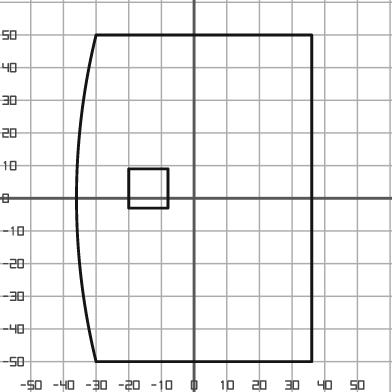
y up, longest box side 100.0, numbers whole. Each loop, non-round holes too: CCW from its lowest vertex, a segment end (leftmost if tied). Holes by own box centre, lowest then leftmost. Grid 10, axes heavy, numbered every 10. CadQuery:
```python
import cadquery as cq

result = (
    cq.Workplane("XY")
    .moveTo(-30.0, -50.0)
    .lineTo(36.0, -50.0)
    .lineTo(36.0, 50.0)
    .lineTo(-30.0, 50.0)
    .threePointArc((-36.0, 0.0), (-30.0, -50.0))
    .close()
    .moveTo(-20.0, -3.0)
    .lineTo(-8.0, -3.0)
    .lineTo(-8.0, 9.0)
    .lineTo(-20.0, 9.0)
    .close()
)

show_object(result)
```